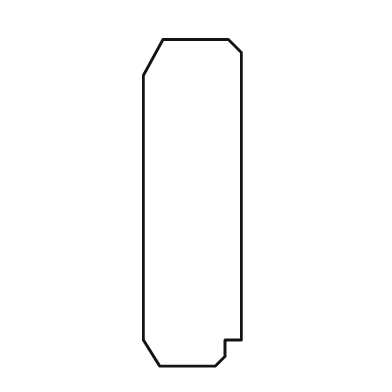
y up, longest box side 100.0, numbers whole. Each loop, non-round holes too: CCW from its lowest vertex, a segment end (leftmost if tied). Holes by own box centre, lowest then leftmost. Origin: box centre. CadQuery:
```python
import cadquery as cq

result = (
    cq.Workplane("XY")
    .moveTo(-10.0, -50.0)
    .lineTo(7.0, -50.0)
    .lineTo(10.0, -47.0)
    .lineTo(10.0, -42.0)
    .lineTo(15.0, -42.0)
    .lineTo(15.0, 46.0)
    .lineTo(11.0, 50.0)
    .lineTo(-9.0, 50.0)
    .lineTo(-15.0, 39.0)
    .lineTo(-15.0, -42.0)
    .close()
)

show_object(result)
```